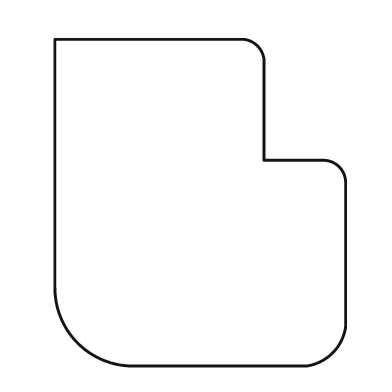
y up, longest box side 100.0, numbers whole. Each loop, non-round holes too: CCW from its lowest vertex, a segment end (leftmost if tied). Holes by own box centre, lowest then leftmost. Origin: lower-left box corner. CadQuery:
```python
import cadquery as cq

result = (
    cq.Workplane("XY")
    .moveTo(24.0, 0.0)
    .lineTo(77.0, 0.0)
    .threePointArc((85.0, 4.0), (89.0, 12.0))
    .lineTo(89.0, 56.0)
    .threePointArc((87.0, 61.0), (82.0, 63.0))
    .lineTo(64.0, 63.0)
    .lineTo(64.0, 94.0)
    .threePointArc((62.0, 98.0), (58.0, 100.0))
    .lineTo(0.0, 100.0)
    .lineTo(0.0, 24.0)
    .threePointArc((7.0, 7.0), (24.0, 0.0))
    .close()
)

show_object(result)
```